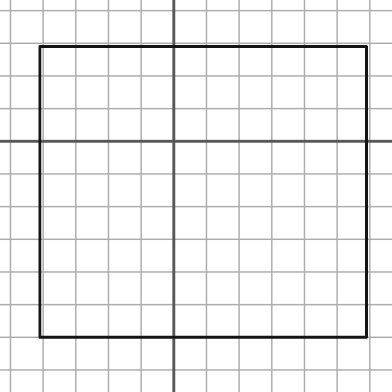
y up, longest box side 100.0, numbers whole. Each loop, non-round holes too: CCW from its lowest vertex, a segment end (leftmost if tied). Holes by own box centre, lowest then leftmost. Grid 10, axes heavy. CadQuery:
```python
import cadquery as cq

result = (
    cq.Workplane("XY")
    .moveTo(-41.0, -60.0)
    .lineTo(59.0, -60.0)
    .lineTo(59.0, 29.0)
    .lineTo(-41.0, 29.0)
    .close()
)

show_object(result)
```